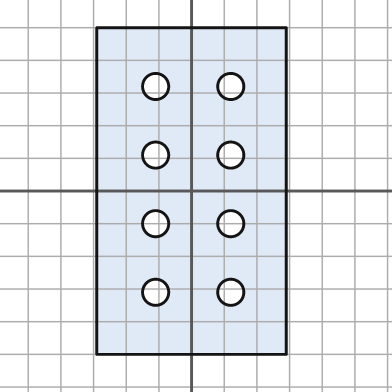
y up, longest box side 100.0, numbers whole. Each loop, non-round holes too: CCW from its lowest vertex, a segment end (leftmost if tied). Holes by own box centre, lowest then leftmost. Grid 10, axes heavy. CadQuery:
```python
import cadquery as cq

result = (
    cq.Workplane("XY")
    .moveTo(-29.0, -50.0)
    .lineTo(29.0, -50.0)
    .lineTo(29.0, 50.0)
    .lineTo(-29.0, 50.0)
    .close()
    .moveTo(-11.0, -31.0)
    .circle(4.0)
    .moveTo(12.0, -31.0)
    .circle(4.0)
    .moveTo(-11.0, -10.0)
    .circle(4.0)
    .moveTo(12.0, -10.0)
    .circle(4.0)
    .moveTo(-11.0, 11.0)
    .circle(4.0)
    .moveTo(12.0, 11.0)
    .circle(4.0)
    .moveTo(-11.0, 32.0)
    .circle(4.0)
    .moveTo(12.0, 32.0)
    .circle(4.0)
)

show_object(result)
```